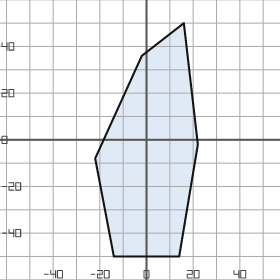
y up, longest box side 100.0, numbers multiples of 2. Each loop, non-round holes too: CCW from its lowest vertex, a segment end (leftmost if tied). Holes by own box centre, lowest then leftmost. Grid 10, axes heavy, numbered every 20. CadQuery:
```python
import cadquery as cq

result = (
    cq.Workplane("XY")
    .moveTo(-14.0, -50.0)
    .lineTo(14.0, -50.0)
    .lineTo(22.0, -2.0)
    .lineTo(16.0, 50.0)
    .lineTo(-2.0, 36.0)
    .lineTo(-22.0, -8.0)
    .close()
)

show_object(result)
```